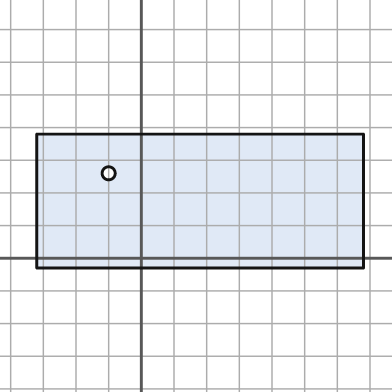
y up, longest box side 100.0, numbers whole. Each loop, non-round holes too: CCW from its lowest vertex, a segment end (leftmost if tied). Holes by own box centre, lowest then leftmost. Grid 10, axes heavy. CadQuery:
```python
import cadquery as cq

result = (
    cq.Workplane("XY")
    .moveTo(-32.0, -3.0)
    .lineTo(68.0, -3.0)
    .lineTo(68.0, 38.0)
    .lineTo(-32.0, 38.0)
    .close()
    .moveTo(-10.0, 26.0)
    .circle(2.0)
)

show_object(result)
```